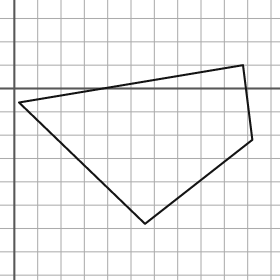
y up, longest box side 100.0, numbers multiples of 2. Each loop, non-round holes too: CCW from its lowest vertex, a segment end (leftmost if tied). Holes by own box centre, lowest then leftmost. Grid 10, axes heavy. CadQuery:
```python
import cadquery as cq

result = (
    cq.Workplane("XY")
    .moveTo(56.0, -58.0)
    .lineTo(102.0, -22.0)
    .lineTo(98.0, 10.0)
    .lineTo(2.0, -6.0)
    .close()
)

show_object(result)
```